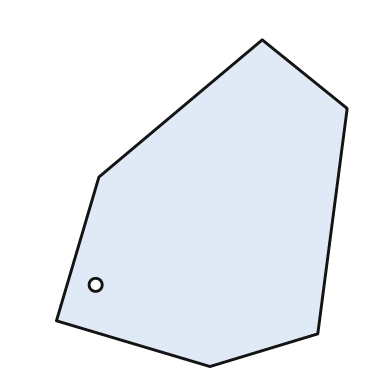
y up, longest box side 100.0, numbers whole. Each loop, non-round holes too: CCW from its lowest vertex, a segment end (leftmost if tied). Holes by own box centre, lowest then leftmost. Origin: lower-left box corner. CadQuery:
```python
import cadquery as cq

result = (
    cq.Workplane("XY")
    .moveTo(47.0, 0.0)
    .lineTo(80.0, 10.0)
    .lineTo(89.0, 79.0)
    .lineTo(63.0, 100.0)
    .lineTo(13.0, 58.0)
    .lineTo(0.0, 14.0)
    .close()
    .moveTo(12.0, 25.0)
    .circle(2.0)
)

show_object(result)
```